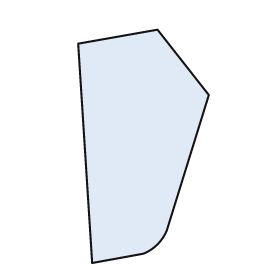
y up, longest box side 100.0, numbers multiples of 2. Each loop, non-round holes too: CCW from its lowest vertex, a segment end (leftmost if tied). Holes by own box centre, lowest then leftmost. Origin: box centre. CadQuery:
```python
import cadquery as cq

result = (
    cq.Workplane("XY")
    .moveTo(-22.0, -50.0)
    .lineTo(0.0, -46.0)
    .threePointArc((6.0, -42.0), (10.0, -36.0))
    .lineTo(28.0, 22.0)
    .lineTo(6.0, 50.0)
    .lineTo(-28.0, 44.0)
    .close()
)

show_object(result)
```